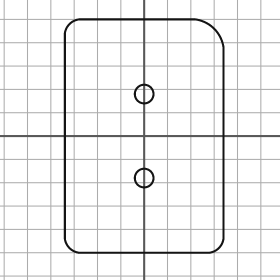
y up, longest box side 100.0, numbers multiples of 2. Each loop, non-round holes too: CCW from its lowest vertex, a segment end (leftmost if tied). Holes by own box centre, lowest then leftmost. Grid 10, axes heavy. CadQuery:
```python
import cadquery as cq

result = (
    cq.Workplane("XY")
    .moveTo(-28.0, -50.0)
    .lineTo(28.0, -50.0)
    .threePointArc((32.0, -48.0), (34.0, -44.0))
    .lineTo(34.0, 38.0)
    .threePointArc((30.0, 46.0), (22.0, 50.0))
    .lineTo(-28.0, 50.0)
    .threePointArc((-32.0, 48.0), (-34.0, 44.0))
    .lineTo(-34.0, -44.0)
    .threePointArc((-32.0, -48.0), (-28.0, -50.0))
    .close()
    .moveTo(0.0, -18.0)
    .circle(4.0)
    .moveTo(0.0, 18.0)
    .circle(4.0)
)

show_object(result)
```